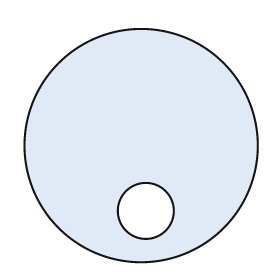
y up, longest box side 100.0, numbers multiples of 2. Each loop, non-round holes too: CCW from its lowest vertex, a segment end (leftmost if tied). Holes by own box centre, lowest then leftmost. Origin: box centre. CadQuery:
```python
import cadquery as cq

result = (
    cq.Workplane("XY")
    .moveTo(0.0, 0.0)
    .circle(50.0)
    .moveTo(2.0, -28.0)
    .circle(12.0)
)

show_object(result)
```